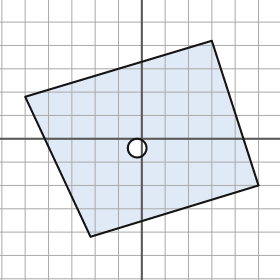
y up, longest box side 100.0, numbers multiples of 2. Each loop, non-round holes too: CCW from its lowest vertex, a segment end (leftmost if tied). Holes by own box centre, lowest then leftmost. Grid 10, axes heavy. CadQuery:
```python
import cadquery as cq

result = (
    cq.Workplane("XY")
    .moveTo(-22.0, -42.0)
    .lineTo(50.0, -20.0)
    .lineTo(30.0, 42.0)
    .lineTo(-50.0, 18.0)
    .close()
    .moveTo(-2.0, -4.0)
    .circle(4.0)
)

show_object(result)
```